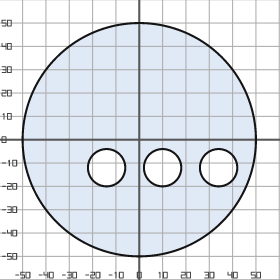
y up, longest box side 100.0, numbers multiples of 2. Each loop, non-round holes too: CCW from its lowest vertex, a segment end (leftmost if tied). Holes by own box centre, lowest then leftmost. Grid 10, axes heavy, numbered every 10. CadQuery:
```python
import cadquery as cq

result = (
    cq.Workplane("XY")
    .moveTo(0.0, 0.0)
    .circle(50.0)
    .moveTo(-14.0, -12.0)
    .circle(8.0)
    .moveTo(10.0, -12.0)
    .circle(8.0)
    .moveTo(34.0, -12.0)
    .circle(8.0)
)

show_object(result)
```